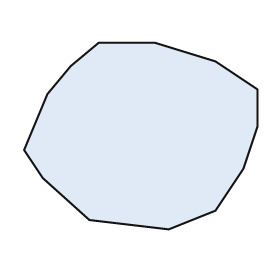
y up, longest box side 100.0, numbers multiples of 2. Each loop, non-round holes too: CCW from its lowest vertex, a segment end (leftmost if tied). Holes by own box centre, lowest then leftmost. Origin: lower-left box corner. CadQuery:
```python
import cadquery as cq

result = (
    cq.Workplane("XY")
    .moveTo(62.0, 0.0)
    .lineTo(82.0, 8.0)
    .lineTo(94.0, 26.0)
    .lineTo(100.0, 44.0)
    .lineTo(100.0, 60.0)
    .lineTo(82.0, 72.0)
    .lineTo(56.0, 80.0)
    .lineTo(32.0, 80.0)
    .lineTo(20.0, 70.0)
    .lineTo(10.0, 58.0)
    .lineTo(0.0, 34.0)
    .lineTo(8.0, 22.0)
    .lineTo(28.0, 4.0)
    .close()
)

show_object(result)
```